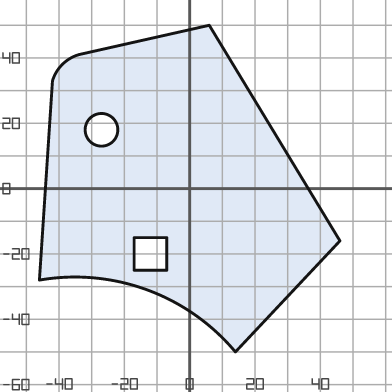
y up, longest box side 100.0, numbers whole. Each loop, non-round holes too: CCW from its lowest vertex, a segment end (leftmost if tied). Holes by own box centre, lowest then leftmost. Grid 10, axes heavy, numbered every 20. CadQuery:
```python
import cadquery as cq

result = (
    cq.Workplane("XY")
    .moveTo(14.0, -50.0)
    .lineTo(46.0, -16.0)
    .lineTo(6.0, 50.0)
    .lineTo(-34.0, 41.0)
    .threePointArc((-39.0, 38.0), (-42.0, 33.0))
    .lineTo(-46.0, -28.0)
    .threePointArc((-13.0, -31.0), (14.0, -50.0))
    .close()
    .moveTo(-17.0, -25.0)
    .lineTo(-7.0, -25.0)
    .lineTo(-7.0, -15.0)
    .lineTo(-17.0, -15.0)
    .close()
    .moveTo(-27.0, 18.0)
    .circle(5.0)
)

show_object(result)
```